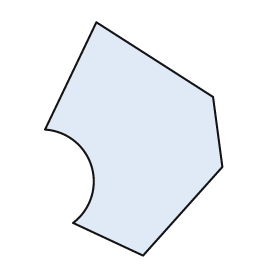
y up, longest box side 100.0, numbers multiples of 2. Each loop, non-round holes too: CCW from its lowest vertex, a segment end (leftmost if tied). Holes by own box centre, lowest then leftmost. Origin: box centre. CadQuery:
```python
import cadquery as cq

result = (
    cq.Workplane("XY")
    .moveTo(4.0, -50.0)
    .lineTo(38.0, -12.0)
    .lineTo(34.0, 18.0)
    .lineTo(-16.0, 50.0)
    .lineTo(-38.0, 4.0)
    .threePointArc((-18.0, -12.0), (-26.0, -36.0))
    .close()
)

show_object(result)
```